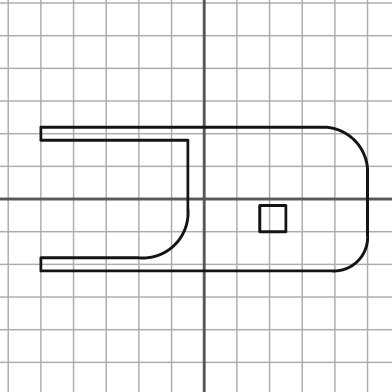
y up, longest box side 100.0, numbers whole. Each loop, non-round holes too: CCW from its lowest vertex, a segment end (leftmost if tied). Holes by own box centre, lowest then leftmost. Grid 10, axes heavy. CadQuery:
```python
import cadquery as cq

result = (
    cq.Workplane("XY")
    .moveTo(-50.0, -22.0)
    .lineTo(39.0, -22.0)
    .threePointArc((47.0, -19.0), (50.0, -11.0))
    .lineTo(50.0, 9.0)
    .threePointArc((46.0, 18.0), (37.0, 22.0))
    .lineTo(-50.0, 22.0)
    .lineTo(-50.0, 18.0)
    .lineTo(-5.0, 18.0)
    .lineTo(-5.0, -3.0)
    .threePointArc((-9.0, -14.0), (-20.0, -18.0))
    .lineTo(-50.0, -18.0)
    .close()
    .moveTo(17.0, -10.0)
    .lineTo(25.0, -10.0)
    .lineTo(25.0, -2.0)
    .lineTo(17.0, -2.0)
    .close()
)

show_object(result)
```